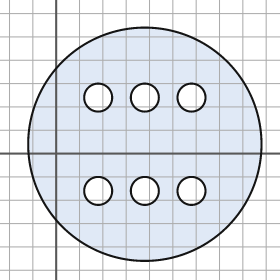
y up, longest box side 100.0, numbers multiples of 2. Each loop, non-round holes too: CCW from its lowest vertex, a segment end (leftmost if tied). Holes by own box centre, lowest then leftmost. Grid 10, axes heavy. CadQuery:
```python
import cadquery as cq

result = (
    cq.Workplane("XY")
    .moveTo(38.0, 4.0)
    .circle(50.0)
    .moveTo(18.0, -16.0)
    .circle(6.0)
    .moveTo(38.0, -16.0)
    .circle(6.0)
    .moveTo(58.0, -16.0)
    .circle(6.0)
    .moveTo(18.0, 24.0)
    .circle(6.0)
    .moveTo(38.0, 24.0)
    .circle(6.0)
    .moveTo(58.0, 24.0)
    .circle(6.0)
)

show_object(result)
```